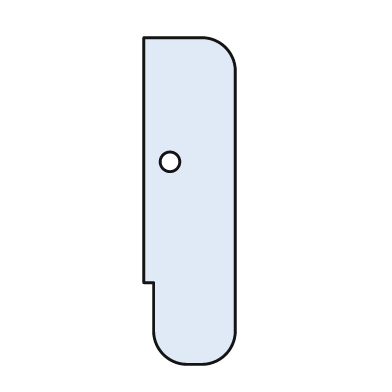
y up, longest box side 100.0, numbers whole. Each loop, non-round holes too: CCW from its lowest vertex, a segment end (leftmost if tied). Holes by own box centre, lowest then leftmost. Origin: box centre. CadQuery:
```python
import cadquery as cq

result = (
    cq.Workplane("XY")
    .moveTo(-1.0, -50.0)
    .lineTo(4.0, -50.0)
    .threePointArc((11.0, -47.0), (14.0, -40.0))
    .lineTo(14.0, 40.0)
    .threePointArc((11.0, 47.0), (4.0, 50.0))
    .lineTo(-14.0, 50.0)
    .lineTo(-14.0, -25.0)
    .lineTo(-11.0, -25.0)
    .lineTo(-11.0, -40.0)
    .threePointArc((-8.0, -47.0), (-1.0, -50.0))
    .close()
    .moveTo(-6.0, 12.0)
    .circle(3.0)
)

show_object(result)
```